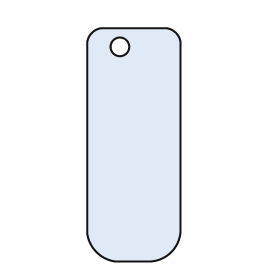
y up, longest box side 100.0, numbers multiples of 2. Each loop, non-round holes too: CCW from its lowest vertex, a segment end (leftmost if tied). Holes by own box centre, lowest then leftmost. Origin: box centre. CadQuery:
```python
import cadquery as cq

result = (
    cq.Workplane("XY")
    .moveTo(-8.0, -50.0)
    .lineTo(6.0, -50.0)
    .threePointArc((16.0, -46.0), (20.0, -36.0))
    .lineTo(20.0, 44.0)
    .threePointArc((18.0, 48.0), (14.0, 50.0))
    .lineTo(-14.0, 50.0)
    .threePointArc((-18.0, 48.0), (-20.0, 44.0))
    .lineTo(-20.0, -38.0)
    .threePointArc((-16.0, -46.0), (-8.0, -50.0))
    .close()
    .moveTo(-6.0, 42.0)
    .circle(4.0)
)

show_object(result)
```